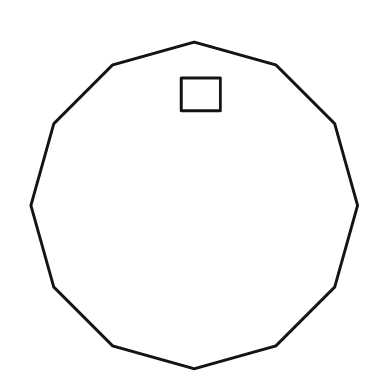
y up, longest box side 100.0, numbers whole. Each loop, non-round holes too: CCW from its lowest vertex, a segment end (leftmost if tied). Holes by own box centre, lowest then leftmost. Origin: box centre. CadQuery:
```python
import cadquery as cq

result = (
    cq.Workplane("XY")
    .moveTo(0.0, -50.0)
    .lineTo(25.0, -43.0)
    .lineTo(43.0, -25.0)
    .lineTo(50.0, 0.0)
    .lineTo(43.0, 25.0)
    .lineTo(25.0, 43.0)
    .lineTo(0.0, 50.0)
    .lineTo(-25.0, 43.0)
    .lineTo(-43.0, 25.0)
    .lineTo(-50.0, 0.0)
    .lineTo(-43.0, -25.0)
    .lineTo(-25.0, -43.0)
    .close()
    .moveTo(-4.0, 29.0)
    .lineTo(8.0, 29.0)
    .lineTo(8.0, 39.0)
    .lineTo(-4.0, 39.0)
    .close()
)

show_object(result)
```